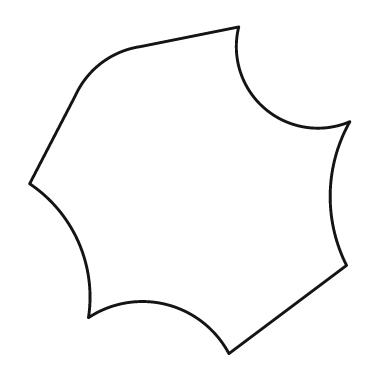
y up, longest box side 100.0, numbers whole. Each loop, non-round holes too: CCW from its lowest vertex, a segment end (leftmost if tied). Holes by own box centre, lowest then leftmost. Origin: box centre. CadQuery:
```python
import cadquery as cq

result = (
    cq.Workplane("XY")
    .moveTo(12.0, -50.0)
    .lineTo(48.0, -23.0)
    .threePointArc((43.0, -1.0), (49.0, 21.0))
    .threePointArc((23.0, 25.0), (15.0, 50.0))
    .lineTo(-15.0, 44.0)
    .threePointArc((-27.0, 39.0), (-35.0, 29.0))
    .lineTo(-49.0, 2.0)
    .threePointArc((-34.0, -16.0), (-31.0, -39.0))
    .threePointArc((-7.0, -35.0), (12.0, -50.0))
    .close()
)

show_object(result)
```